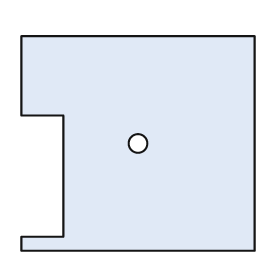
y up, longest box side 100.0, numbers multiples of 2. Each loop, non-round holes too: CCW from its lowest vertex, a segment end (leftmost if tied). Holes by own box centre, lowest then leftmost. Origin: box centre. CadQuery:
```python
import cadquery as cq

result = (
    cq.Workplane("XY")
    .moveTo(-50.0, -46.0)
    .lineTo(50.0, -46.0)
    .lineTo(50.0, 46.0)
    .lineTo(-50.0, 46.0)
    .lineTo(-50.0, 12.0)
    .lineTo(-32.0, 12.0)
    .lineTo(-32.0, -40.0)
    .lineTo(-50.0, -40.0)
    .close()
    .moveTo(0.0, 0.0)
    .circle(4.0)
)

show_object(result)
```